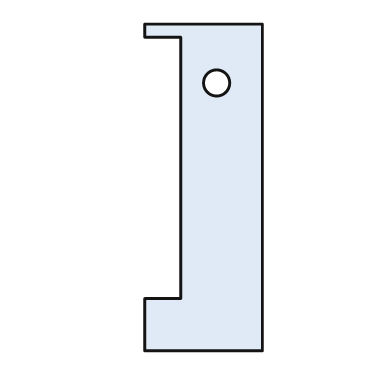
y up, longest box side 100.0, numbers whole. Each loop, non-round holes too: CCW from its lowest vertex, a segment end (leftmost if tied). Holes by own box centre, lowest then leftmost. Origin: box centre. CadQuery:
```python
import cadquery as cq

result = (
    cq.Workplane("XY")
    .moveTo(-18.0, -50.0)
    .lineTo(18.0, -50.0)
    .lineTo(18.0, 50.0)
    .lineTo(-18.0, 50.0)
    .lineTo(-18.0, 46.0)
    .lineTo(-7.0, 46.0)
    .lineTo(-7.0, -34.0)
    .lineTo(-18.0, -34.0)
    .close()
    .moveTo(4.0, 32.0)
    .circle(4.0)
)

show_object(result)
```